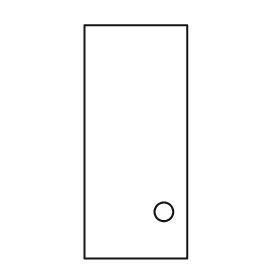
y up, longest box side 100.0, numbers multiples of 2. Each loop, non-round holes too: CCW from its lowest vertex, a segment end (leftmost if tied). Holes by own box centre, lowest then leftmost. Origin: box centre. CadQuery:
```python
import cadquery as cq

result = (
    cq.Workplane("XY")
    .moveTo(-22.0, -50.0)
    .lineTo(22.0, -50.0)
    .lineTo(22.0, 50.0)
    .lineTo(-22.0, 50.0)
    .close()
    .moveTo(12.0, -30.0)
    .circle(4.0)
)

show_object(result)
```